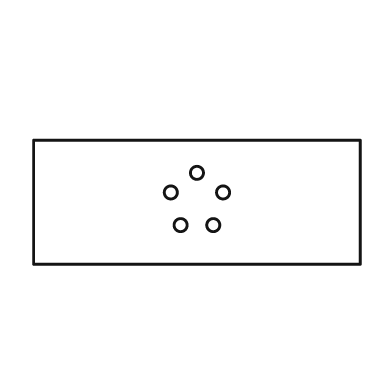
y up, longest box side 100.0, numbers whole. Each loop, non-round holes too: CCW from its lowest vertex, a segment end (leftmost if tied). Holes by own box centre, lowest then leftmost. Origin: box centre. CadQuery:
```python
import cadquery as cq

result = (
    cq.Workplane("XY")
    .moveTo(-50.0, -19.0)
    .lineTo(50.0, -19.0)
    .lineTo(50.0, 19.0)
    .lineTo(-50.0, 19.0)
    .close()
    .moveTo(-5.0, -7.0)
    .circle(2.0)
    .moveTo(5.0, -7.0)
    .circle(2.0)
    .moveTo(-8.0, 3.0)
    .circle(2.0)
    .moveTo(8.0, 3.0)
    .circle(2.0)
    .moveTo(0.0, 9.0)
    .circle(2.0)
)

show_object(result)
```